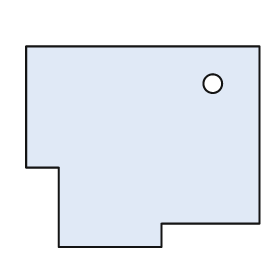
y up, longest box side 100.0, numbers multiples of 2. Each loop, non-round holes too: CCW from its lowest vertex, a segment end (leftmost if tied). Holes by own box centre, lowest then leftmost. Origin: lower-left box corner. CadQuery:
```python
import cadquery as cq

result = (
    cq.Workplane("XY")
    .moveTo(14.0, 0.0)
    .lineTo(58.0, 0.0)
    .lineTo(58.0, 10.0)
    .lineTo(100.0, 10.0)
    .lineTo(100.0, 86.0)
    .lineTo(0.0, 86.0)
    .lineTo(0.0, 34.0)
    .lineTo(14.0, 34.0)
    .close()
    .moveTo(80.0, 70.0)
    .circle(4.0)
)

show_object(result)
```